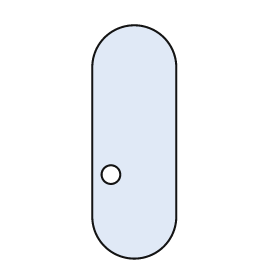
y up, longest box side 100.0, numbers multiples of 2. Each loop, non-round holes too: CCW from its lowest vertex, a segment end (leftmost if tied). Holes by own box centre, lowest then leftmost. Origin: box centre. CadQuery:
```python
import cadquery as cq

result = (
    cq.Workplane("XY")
    .moveTo(-18.0, -32.0)
    .threePointArc((0.0, -50.0), (18.0, -32.0))
    .lineTo(18.0, 32.0)
    .threePointArc((0.0, 50.0), (-18.0, 32.0))
    .close()
    .moveTo(-10.0, -14.0)
    .circle(4.0)
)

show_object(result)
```